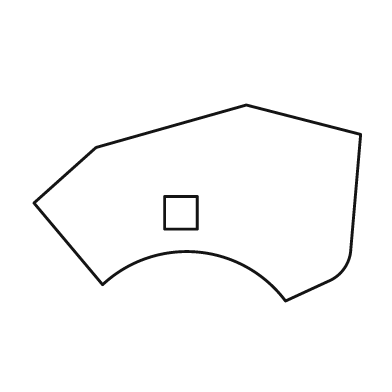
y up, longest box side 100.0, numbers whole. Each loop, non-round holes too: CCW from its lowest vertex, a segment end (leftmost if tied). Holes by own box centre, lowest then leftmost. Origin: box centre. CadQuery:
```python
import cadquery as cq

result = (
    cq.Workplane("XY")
    .moveTo(27.0, -30.0)
    .lineTo(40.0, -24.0)
    .threePointArc((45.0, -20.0), (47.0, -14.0))
    .lineTo(50.0, 21.0)
    .lineTo(15.0, 30.0)
    .lineTo(-31.0, 17.0)
    .lineTo(-50.0, 0.0)
    .lineTo(-29.0, -25.0)
    .threePointArc((0.0, -15.0), (27.0, -30.0))
    .close()
    .moveTo(-10.0, -8.0)
    .lineTo(0.0, -8.0)
    .lineTo(0.0, 2.0)
    .lineTo(-10.0, 2.0)
    .close()
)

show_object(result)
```